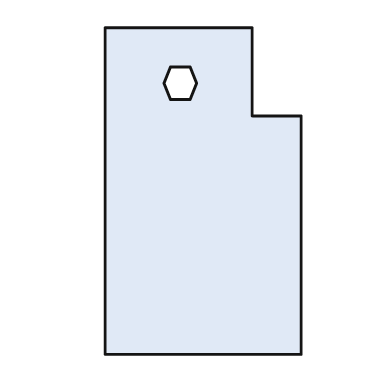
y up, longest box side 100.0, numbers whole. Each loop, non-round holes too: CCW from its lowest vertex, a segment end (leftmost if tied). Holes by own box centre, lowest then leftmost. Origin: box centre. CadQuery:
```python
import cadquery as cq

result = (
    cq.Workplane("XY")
    .moveTo(-30.0, -50.0)
    .lineTo(30.0, -50.0)
    .lineTo(30.0, 23.0)
    .lineTo(15.0, 23.0)
    .lineTo(15.0, 50.0)
    .lineTo(-30.0, 50.0)
    .close()
    .moveTo(-10.0, 28.0)
    .lineTo(-4.0, 28.0)
    .lineTo(-2.0, 33.0)
    .lineTo(-4.0, 38.0)
    .lineTo(-10.0, 38.0)
    .lineTo(-12.0, 33.0)
    .close()
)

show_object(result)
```